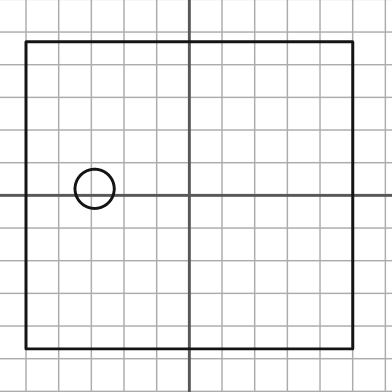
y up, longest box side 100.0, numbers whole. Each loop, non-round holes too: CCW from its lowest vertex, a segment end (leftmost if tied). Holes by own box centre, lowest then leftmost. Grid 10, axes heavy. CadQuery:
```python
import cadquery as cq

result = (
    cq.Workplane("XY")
    .moveTo(-50.0, -47.0)
    .lineTo(50.0, -47.0)
    .lineTo(50.0, 47.0)
    .lineTo(-50.0, 47.0)
    .close()
    .moveTo(-29.0, 2.0)
    .circle(6.0)
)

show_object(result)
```